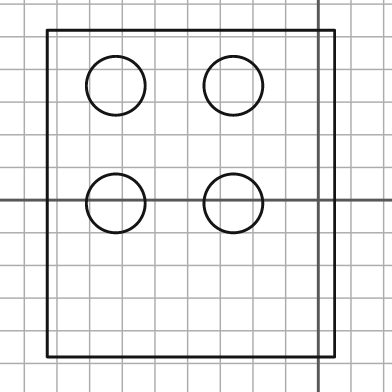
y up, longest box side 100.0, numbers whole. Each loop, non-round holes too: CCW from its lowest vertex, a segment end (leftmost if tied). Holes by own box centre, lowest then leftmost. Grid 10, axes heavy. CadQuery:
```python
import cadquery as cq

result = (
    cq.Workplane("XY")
    .moveTo(-83.0, -48.0)
    .lineTo(5.0, -48.0)
    .lineTo(5.0, 52.0)
    .lineTo(-83.0, 52.0)
    .close()
    .moveTo(-62.0, -1.0)
    .circle(9.0)
    .moveTo(-26.0, -1.0)
    .circle(9.0)
    .moveTo(-62.0, 35.0)
    .circle(9.0)
    .moveTo(-26.0, 35.0)
    .circle(9.0)
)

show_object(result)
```